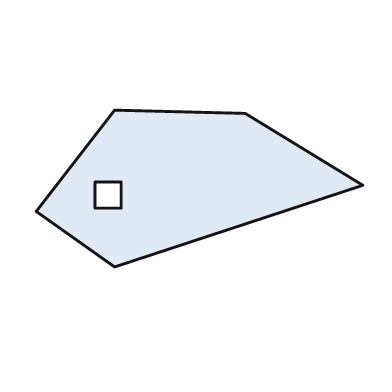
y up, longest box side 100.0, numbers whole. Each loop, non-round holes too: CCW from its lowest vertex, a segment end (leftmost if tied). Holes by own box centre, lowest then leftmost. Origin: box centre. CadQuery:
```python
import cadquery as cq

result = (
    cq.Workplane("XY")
    .moveTo(-26.0, -24.0)
    .lineTo(50.0, 1.0)
    .lineTo(14.0, 23.0)
    .lineTo(-26.0, 24.0)
    .lineTo(-50.0, -7.0)
    .close()
    .moveTo(-32.0, -6.0)
    .lineTo(-24.0, -6.0)
    .lineTo(-24.0, 2.0)
    .lineTo(-32.0, 2.0)
    .close()
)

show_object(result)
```